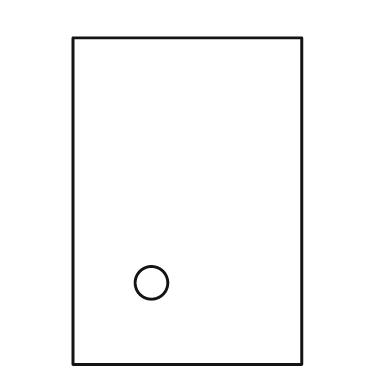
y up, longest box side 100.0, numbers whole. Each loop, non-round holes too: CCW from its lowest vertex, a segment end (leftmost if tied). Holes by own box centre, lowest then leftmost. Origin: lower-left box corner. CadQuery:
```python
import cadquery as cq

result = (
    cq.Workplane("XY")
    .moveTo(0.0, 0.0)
    .lineTo(70.0, 0.0)
    .lineTo(70.0, 100.0)
    .lineTo(0.0, 100.0)
    .close()
    .moveTo(24.0, 25.0)
    .circle(5.0)
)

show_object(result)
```